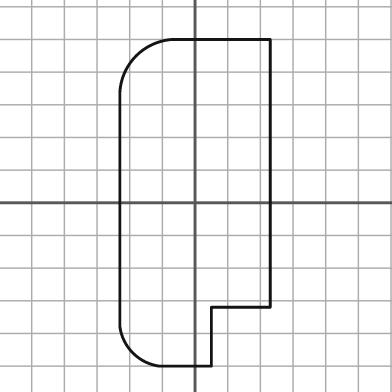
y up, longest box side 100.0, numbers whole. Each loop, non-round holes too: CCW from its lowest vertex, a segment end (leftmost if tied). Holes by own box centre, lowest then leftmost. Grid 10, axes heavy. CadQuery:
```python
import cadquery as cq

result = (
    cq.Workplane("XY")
    .moveTo(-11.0, -50.0)
    .lineTo(5.0, -50.0)
    .lineTo(5.0, -32.0)
    .lineTo(23.0, -32.0)
    .lineTo(23.0, 50.0)
    .lineTo(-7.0, 50.0)
    .threePointArc((-18.0, 45.0), (-23.0, 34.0))
    .lineTo(-23.0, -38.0)
    .threePointArc((-19.0, -46.0), (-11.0, -50.0))
    .close()
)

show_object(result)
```